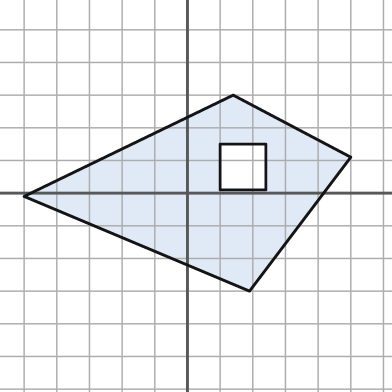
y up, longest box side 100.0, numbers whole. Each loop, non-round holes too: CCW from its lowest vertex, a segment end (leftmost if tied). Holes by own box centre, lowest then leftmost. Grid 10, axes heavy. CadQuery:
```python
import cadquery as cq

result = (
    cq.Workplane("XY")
    .moveTo(19.0, -30.0)
    .lineTo(50.0, 11.0)
    .lineTo(14.0, 30.0)
    .lineTo(-50.0, -1.0)
    .close()
    .moveTo(10.0, 1.0)
    .lineTo(24.0, 1.0)
    .lineTo(24.0, 15.0)
    .lineTo(10.0, 15.0)
    .close()
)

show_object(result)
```